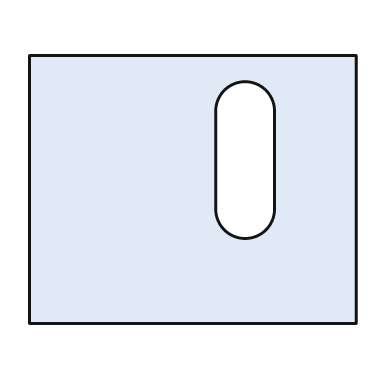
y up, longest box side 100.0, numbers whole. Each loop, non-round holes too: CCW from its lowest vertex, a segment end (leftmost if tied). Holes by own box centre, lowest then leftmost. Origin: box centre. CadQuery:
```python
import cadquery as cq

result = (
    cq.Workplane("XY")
    .moveTo(-50.0, -41.0)
    .lineTo(50.0, -41.0)
    .lineTo(50.0, 41.0)
    .lineTo(-50.0, 41.0)
    .close()
    .moveTo(7.0, -6.0)
    .threePointArc((16.0, -15.0), (25.0, -6.0))
    .lineTo(25.0, 24.0)
    .threePointArc((16.0, 33.0), (7.0, 24.0))
    .close()
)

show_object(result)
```